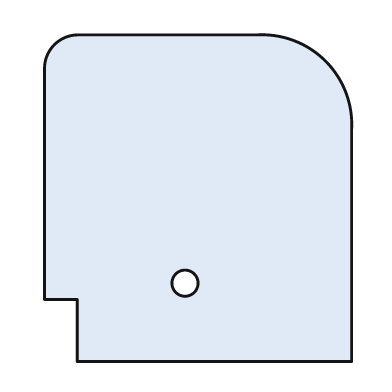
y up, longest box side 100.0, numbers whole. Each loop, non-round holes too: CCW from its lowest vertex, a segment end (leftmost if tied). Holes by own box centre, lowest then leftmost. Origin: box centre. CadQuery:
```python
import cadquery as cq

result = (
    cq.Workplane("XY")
    .moveTo(-37.0, -50.0)
    .lineTo(47.0, -50.0)
    .lineTo(47.0, 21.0)
    .threePointArc((39.0, 42.0), (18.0, 50.0))
    .lineTo(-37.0, 50.0)
    .threePointArc((-44.0, 47.0), (-47.0, 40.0))
    .lineTo(-47.0, -31.0)
    .lineTo(-37.0, -31.0)
    .close()
    .moveTo(-4.0, -26.0)
    .circle(4.0)
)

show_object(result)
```